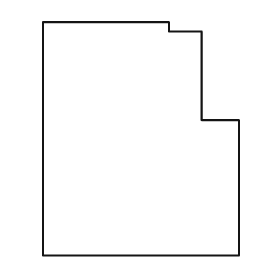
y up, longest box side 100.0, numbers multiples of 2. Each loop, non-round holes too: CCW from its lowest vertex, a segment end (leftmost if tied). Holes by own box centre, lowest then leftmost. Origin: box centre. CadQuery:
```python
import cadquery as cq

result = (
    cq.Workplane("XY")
    .moveTo(-42.0, -50.0)
    .lineTo(42.0, -50.0)
    .lineTo(42.0, 8.0)
    .lineTo(26.0, 8.0)
    .lineTo(26.0, 46.0)
    .lineTo(12.0, 46.0)
    .lineTo(12.0, 50.0)
    .lineTo(-42.0, 50.0)
    .close()
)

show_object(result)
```